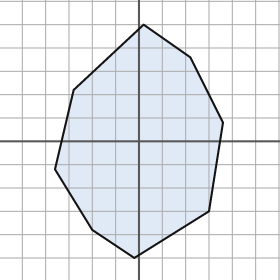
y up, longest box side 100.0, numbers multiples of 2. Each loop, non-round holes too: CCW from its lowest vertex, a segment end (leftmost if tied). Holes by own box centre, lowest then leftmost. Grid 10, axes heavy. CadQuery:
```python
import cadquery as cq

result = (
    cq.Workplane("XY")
    .moveTo(-2.0, -50.0)
    .lineTo(30.0, -30.0)
    .lineTo(36.0, 8.0)
    .lineTo(22.0, 36.0)
    .lineTo(2.0, 50.0)
    .lineTo(-28.0, 22.0)
    .lineTo(-36.0, -12.0)
    .lineTo(-20.0, -38.0)
    .close()
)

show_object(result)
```